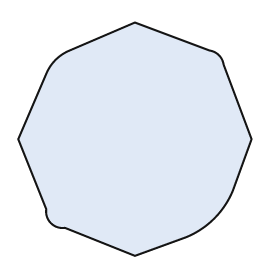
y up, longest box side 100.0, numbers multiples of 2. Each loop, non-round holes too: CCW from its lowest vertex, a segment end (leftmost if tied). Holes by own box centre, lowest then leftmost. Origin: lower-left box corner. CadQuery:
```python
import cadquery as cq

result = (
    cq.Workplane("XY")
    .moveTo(50.0, 0.0)
    .lineTo(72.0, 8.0)
    .threePointArc((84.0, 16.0), (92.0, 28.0))
    .lineTo(100.0, 50.0)
    .lineTo(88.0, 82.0)
    .threePointArc((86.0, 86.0), (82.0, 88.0))
    .lineTo(50.0, 100.0)
    .lineTo(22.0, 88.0)
    .threePointArc((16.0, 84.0), (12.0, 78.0))
    .lineTo(0.0, 50.0)
    .lineTo(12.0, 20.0)
    .threePointArc((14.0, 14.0), (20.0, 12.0))
    .close()
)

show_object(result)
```